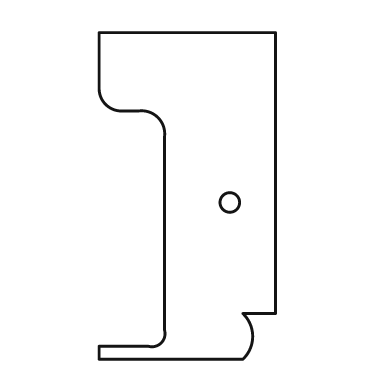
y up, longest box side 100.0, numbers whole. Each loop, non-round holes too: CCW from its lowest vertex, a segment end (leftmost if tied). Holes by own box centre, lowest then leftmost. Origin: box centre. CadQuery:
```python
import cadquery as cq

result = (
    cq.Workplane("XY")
    .moveTo(-27.0, -50.0)
    .lineTo(17.0, -50.0)
    .threePointArc((20.0, -43.0), (17.0, -36.0))
    .lineTo(27.0, -36.0)
    .lineTo(27.0, 50.0)
    .lineTo(-27.0, 50.0)
    .lineTo(-27.0, 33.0)
    .threePointArc((-25.0, 28.0), (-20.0, 26.0))
    .lineTo(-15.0, 26.0)
    .threePointArc((-9.0, 24.0), (-7.0, 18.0))
    .lineTo(-7.0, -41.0)
    .threePointArc((-8.0, -45.0), (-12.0, -46.0))
    .lineTo(-27.0, -46.0)
    .close()
    .moveTo(13.0, -2.0)
    .circle(3.0)
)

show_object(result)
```